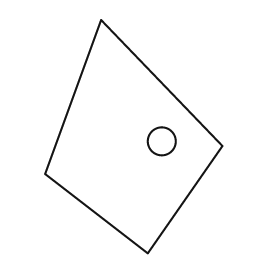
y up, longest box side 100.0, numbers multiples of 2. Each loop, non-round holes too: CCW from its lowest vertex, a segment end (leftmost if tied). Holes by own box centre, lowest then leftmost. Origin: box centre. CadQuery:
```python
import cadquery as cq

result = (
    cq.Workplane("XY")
    .moveTo(6.0, -50.0)
    .lineTo(38.0, -4.0)
    .lineTo(-14.0, 50.0)
    .lineTo(-38.0, -16.0)
    .close()
    .moveTo(12.0, -2.0)
    .circle(6.0)
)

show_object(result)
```